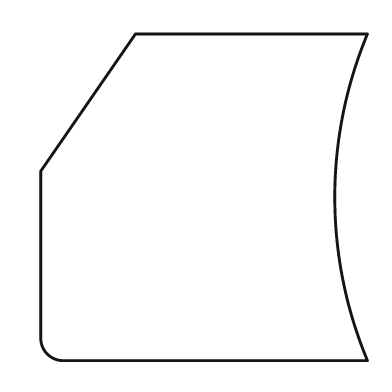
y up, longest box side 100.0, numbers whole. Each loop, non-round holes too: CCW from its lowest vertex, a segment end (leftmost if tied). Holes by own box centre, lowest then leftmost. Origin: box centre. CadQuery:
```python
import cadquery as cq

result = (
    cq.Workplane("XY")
    .moveTo(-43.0, -50.0)
    .lineTo(50.0, -50.0)
    .threePointArc((40.0, 0.0), (50.0, 50.0))
    .lineTo(-21.0, 50.0)
    .lineTo(-50.0, 8.0)
    .lineTo(-50.0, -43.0)
    .threePointArc((-48.0, -48.0), (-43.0, -50.0))
    .close()
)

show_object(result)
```